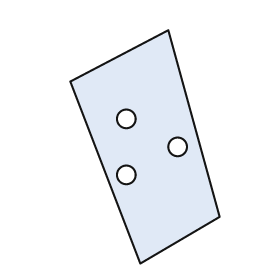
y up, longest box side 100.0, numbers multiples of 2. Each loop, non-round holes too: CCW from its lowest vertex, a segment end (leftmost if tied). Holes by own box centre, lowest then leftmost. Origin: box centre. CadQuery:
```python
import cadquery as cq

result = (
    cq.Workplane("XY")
    .moveTo(-2.0, -50.0)
    .lineTo(32.0, -30.0)
    .lineTo(10.0, 50.0)
    .lineTo(-32.0, 28.0)
    .close()
    .moveTo(-8.0, -12.0)
    .circle(4.0)
    .moveTo(14.0, 0.0)
    .circle(4.0)
    .moveTo(-8.0, 12.0)
    .circle(4.0)
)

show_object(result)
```